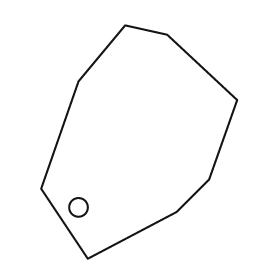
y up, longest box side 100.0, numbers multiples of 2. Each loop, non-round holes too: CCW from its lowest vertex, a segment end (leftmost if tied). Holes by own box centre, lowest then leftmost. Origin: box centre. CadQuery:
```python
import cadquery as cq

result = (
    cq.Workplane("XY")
    .moveTo(-22.0, -50.0)
    .lineTo(16.0, -30.0)
    .lineTo(30.0, -16.0)
    .lineTo(42.0, 18.0)
    .lineTo(12.0, 46.0)
    .lineTo(-6.0, 50.0)
    .lineTo(-26.0, 26.0)
    .lineTo(-42.0, -20.0)
    .close()
    .moveTo(-26.0, -28.0)
    .circle(4.0)
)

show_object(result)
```